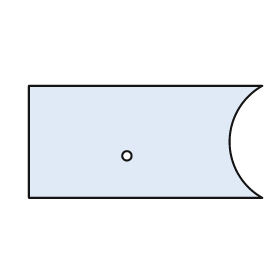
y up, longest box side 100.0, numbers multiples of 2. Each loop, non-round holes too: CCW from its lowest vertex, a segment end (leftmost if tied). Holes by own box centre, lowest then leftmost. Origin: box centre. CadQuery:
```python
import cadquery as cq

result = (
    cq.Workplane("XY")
    .moveTo(-50.0, -24.0)
    .lineTo(50.0, -24.0)
    .threePointArc((36.0, 0.0), (50.0, 24.0))
    .lineTo(-50.0, 24.0)
    .close()
    .moveTo(-8.0, -6.0)
    .circle(2.0)
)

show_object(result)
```